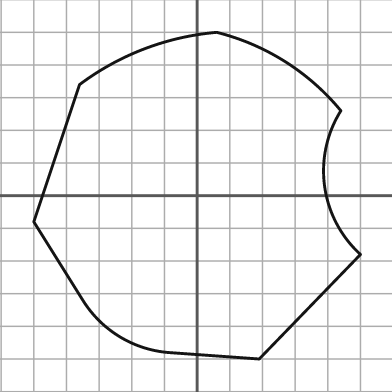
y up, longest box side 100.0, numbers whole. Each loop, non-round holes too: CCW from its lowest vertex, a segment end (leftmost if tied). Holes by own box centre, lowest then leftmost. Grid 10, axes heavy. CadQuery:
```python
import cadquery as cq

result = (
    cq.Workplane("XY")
    .moveTo(19.0, -50.0)
    .lineTo(50.0, -18.0)
    .threePointArc((39.0, 3.0), (44.0, 26.0))
    .threePointArc((27.0, 41.0), (6.0, 50.0))
    .threePointArc((-16.0, 45.0), (-36.0, 34.0))
    .lineTo(-50.0, -8.0)
    .lineTo(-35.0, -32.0)
    .threePointArc((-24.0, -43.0), (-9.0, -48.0))
    .close()
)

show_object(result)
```